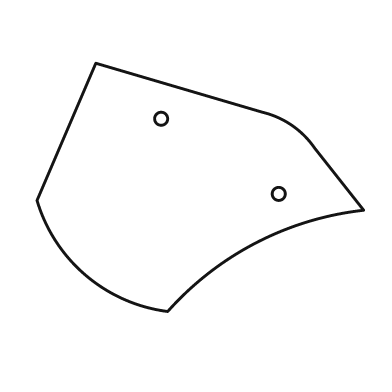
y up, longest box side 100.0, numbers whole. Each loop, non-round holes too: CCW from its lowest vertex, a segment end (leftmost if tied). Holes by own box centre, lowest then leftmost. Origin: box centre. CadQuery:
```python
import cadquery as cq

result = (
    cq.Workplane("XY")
    .moveTo(-10.0, -38.0)
    .threePointArc((17.0, -17.0), (50.0, -7.0))
    .lineTo(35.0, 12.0)
    .threePointArc((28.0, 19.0), (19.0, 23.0))
    .lineTo(-32.0, 38.0)
    .lineTo(-50.0, -4.0)
    .threePointArc((-35.0, -27.0), (-10.0, -38.0))
    .close()
    .moveTo(24.0, -2.0)
    .circle(2.0)
    .moveTo(-12.0, 21.0)
    .circle(2.0)
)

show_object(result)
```